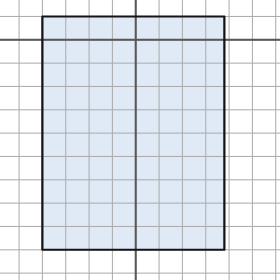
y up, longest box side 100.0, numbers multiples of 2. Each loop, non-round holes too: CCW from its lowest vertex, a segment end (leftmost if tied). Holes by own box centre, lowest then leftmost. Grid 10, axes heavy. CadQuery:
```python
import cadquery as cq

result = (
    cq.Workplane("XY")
    .moveTo(-40.0, -90.0)
    .lineTo(38.0, -90.0)
    .lineTo(38.0, 10.0)
    .lineTo(-40.0, 10.0)
    .close()
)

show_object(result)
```